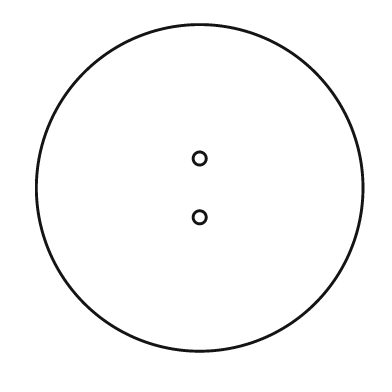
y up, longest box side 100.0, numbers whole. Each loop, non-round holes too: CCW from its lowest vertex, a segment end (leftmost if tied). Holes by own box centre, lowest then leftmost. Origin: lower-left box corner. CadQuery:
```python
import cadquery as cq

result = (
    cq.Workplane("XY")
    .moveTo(50.0, 50.0)
    .circle(50.0)
    .moveTo(50.0, 41.0)
    .circle(2.0)
    .moveTo(50.0, 59.0)
    .circle(2.0)
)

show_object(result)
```